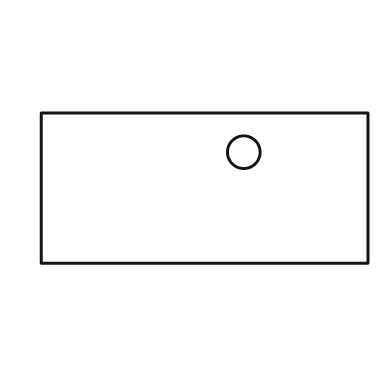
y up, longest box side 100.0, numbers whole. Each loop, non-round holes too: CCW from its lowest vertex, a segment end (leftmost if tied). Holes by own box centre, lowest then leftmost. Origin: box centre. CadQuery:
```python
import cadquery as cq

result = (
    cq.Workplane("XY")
    .moveTo(-50.0, -23.0)
    .lineTo(50.0, -23.0)
    .lineTo(50.0, 23.0)
    .lineTo(-50.0, 23.0)
    .close()
    .moveTo(12.0, 11.0)
    .circle(5.0)
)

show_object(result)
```